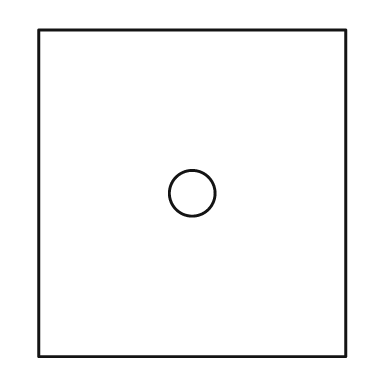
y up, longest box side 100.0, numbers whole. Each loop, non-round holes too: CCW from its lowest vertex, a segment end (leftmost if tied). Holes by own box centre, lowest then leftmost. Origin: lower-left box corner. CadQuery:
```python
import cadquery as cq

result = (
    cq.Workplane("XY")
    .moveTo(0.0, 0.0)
    .lineTo(94.0, 0.0)
    .lineTo(94.0, 100.0)
    .lineTo(0.0, 100.0)
    .close()
    .moveTo(47.0, 50.0)
    .circle(7.0)
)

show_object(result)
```